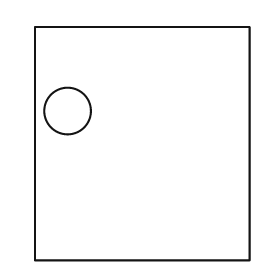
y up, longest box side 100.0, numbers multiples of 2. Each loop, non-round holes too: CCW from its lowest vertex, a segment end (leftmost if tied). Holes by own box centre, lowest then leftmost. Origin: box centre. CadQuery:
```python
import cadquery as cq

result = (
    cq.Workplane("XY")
    .moveTo(-46.0, -50.0)
    .lineTo(46.0, -50.0)
    .lineTo(46.0, 50.0)
    .lineTo(-46.0, 50.0)
    .close()
    .moveTo(-32.0, 14.0)
    .circle(10.0)
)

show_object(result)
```